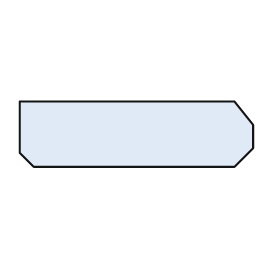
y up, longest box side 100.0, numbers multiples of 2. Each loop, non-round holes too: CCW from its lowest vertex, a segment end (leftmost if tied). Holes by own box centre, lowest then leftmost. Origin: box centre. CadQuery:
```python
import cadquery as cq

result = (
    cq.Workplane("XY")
    .moveTo(-44.0, -14.0)
    .lineTo(42.0, -14.0)
    .lineTo(50.0, -6.0)
    .lineTo(50.0, 4.0)
    .lineTo(42.0, 14.0)
    .lineTo(-50.0, 14.0)
    .lineTo(-50.0, -8.0)
    .close()
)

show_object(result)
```